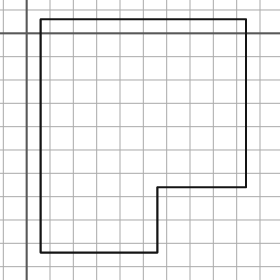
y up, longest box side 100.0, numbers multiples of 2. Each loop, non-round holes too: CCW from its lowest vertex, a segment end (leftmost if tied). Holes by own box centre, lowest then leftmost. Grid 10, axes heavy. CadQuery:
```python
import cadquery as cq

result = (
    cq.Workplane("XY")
    .moveTo(6.0, -94.0)
    .lineTo(56.0, -94.0)
    .lineTo(56.0, -66.0)
    .lineTo(94.0, -66.0)
    .lineTo(94.0, 6.0)
    .lineTo(6.0, 6.0)
    .close()
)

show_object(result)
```